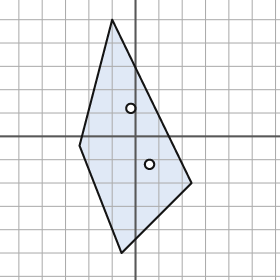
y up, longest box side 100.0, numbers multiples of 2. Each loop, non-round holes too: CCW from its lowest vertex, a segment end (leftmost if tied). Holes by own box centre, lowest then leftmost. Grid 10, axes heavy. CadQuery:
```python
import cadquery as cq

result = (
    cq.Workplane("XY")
    .moveTo(-6.0, -50.0)
    .lineTo(24.0, -20.0)
    .lineTo(-10.0, 50.0)
    .lineTo(-24.0, -4.0)
    .close()
    .moveTo(6.0, -12.0)
    .circle(2.0)
    .moveTo(-2.0, 12.0)
    .circle(2.0)
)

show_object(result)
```